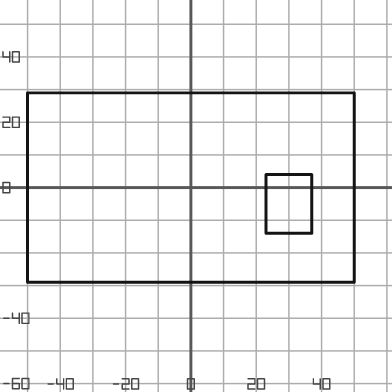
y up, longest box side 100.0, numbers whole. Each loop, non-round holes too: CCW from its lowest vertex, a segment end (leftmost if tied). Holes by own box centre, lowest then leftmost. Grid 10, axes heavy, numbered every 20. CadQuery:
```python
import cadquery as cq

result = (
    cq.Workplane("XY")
    .moveTo(-50.0, -29.0)
    .lineTo(50.0, -29.0)
    .lineTo(50.0, 29.0)
    .lineTo(-50.0, 29.0)
    .close()
    .moveTo(23.0, -14.0)
    .lineTo(37.0, -14.0)
    .lineTo(37.0, 4.0)
    .lineTo(23.0, 4.0)
    .close()
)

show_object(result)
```